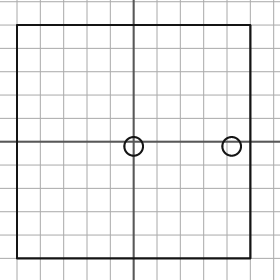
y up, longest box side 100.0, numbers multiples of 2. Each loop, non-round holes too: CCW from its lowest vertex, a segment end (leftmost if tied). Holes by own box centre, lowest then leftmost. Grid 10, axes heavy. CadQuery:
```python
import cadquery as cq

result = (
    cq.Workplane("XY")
    .moveTo(-50.0, -50.0)
    .lineTo(50.0, -50.0)
    .lineTo(50.0, 50.0)
    .lineTo(-50.0, 50.0)
    .close()
    .moveTo(0.0, -2.0)
    .circle(4.0)
    .moveTo(42.0, -2.0)
    .circle(4.0)
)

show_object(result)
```